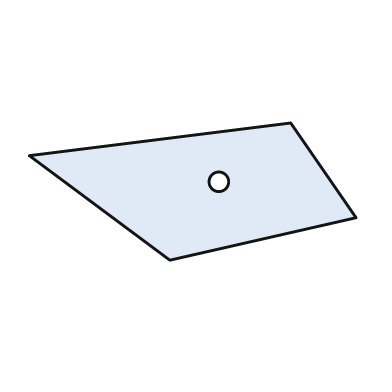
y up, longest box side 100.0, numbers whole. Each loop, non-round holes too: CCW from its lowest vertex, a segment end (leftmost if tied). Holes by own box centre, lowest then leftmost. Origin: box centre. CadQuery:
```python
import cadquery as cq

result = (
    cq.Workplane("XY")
    .moveTo(-7.0, -21.0)
    .lineTo(50.0, -8.0)
    .lineTo(30.0, 21.0)
    .lineTo(-50.0, 11.0)
    .close()
    .moveTo(8.0, 3.0)
    .circle(3.0)
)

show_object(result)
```